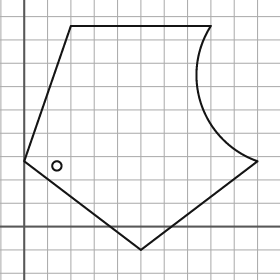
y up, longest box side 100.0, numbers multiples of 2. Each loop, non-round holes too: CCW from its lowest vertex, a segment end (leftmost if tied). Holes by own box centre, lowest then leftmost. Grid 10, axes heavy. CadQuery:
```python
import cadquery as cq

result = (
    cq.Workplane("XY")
    .moveTo(50.0, -10.0)
    .lineTo(100.0, 28.0)
    .threePointArc((76.0, 52.0), (80.0, 86.0))
    .lineTo(20.0, 86.0)
    .lineTo(0.0, 28.0)
    .close()
    .moveTo(14.0, 26.0)
    .circle(2.0)
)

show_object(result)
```